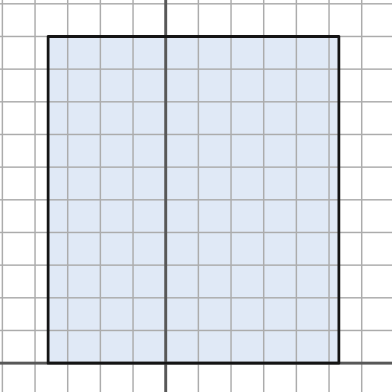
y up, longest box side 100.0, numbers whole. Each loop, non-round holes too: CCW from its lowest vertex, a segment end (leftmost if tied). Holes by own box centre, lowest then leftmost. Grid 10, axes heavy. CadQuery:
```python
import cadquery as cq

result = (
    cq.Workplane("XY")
    .moveTo(-36.0, 0.0)
    .lineTo(53.0, 0.0)
    .lineTo(53.0, 100.0)
    .lineTo(-36.0, 100.0)
    .close()
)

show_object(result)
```